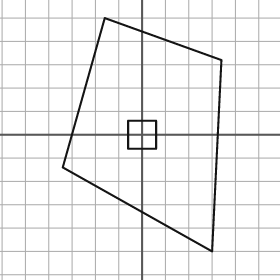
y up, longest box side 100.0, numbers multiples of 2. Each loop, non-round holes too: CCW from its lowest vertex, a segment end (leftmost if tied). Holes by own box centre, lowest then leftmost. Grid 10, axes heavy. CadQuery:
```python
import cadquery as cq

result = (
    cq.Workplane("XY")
    .moveTo(30.0, -50.0)
    .lineTo(34.0, 32.0)
    .lineTo(-16.0, 50.0)
    .lineTo(-34.0, -14.0)
    .close()
    .moveTo(-6.0, -6.0)
    .lineTo(6.0, -6.0)
    .lineTo(6.0, 6.0)
    .lineTo(-6.0, 6.0)
    .close()
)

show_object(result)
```